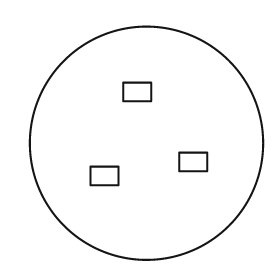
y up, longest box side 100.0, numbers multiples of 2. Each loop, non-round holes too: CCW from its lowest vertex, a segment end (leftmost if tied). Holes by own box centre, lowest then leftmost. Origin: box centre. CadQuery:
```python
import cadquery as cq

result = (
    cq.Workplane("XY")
    .moveTo(0.0, 0.0)
    .circle(50.0)
    .moveTo(-24.0, -18.0)
    .lineTo(-12.0, -18.0)
    .lineTo(-12.0, -10.0)
    .lineTo(-24.0, -10.0)
    .close()
    .moveTo(14.0, -12.0)
    .lineTo(26.0, -12.0)
    .lineTo(26.0, -4.0)
    .lineTo(14.0, -4.0)
    .close()
    .moveTo(-10.0, 18.0)
    .lineTo(2.0, 18.0)
    .lineTo(2.0, 26.0)
    .lineTo(-10.0, 26.0)
    .close()
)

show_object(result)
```